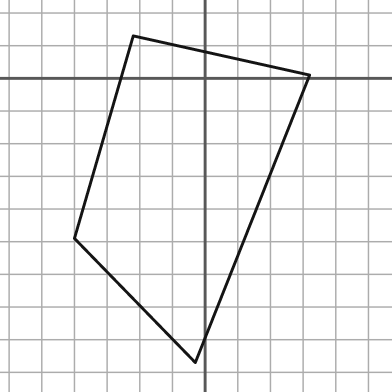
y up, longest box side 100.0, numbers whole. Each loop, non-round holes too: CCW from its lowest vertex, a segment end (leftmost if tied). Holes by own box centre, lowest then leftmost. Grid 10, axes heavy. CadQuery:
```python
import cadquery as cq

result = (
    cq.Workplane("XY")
    .moveTo(-3.0, -87.0)
    .lineTo(32.0, 1.0)
    .lineTo(-22.0, 13.0)
    .lineTo(-40.0, -49.0)
    .close()
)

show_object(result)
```